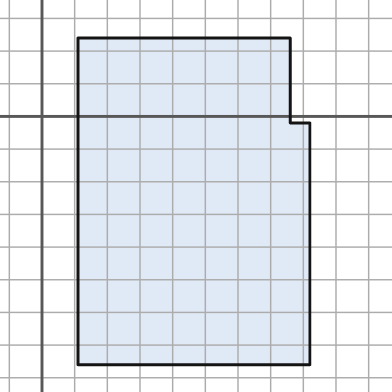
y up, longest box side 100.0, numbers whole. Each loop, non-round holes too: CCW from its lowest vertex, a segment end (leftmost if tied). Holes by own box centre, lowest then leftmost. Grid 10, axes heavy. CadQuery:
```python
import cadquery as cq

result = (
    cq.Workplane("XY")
    .moveTo(11.0, -76.0)
    .lineTo(82.0, -76.0)
    .lineTo(82.0, -2.0)
    .lineTo(76.0, -2.0)
    .lineTo(76.0, 24.0)
    .lineTo(11.0, 24.0)
    .close()
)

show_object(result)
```